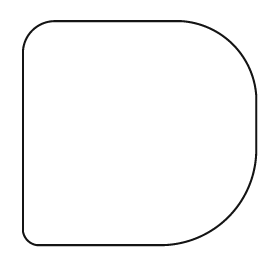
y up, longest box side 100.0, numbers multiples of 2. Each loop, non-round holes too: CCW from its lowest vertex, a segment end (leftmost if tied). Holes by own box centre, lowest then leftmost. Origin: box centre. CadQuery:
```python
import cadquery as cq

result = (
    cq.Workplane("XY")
    .moveTo(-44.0, -48.0)
    .lineTo(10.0, -48.0)
    .threePointArc((38.0, -36.0), (50.0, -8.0))
    .lineTo(50.0, 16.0)
    .threePointArc((40.0, 38.0), (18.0, 48.0))
    .lineTo(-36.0, 48.0)
    .threePointArc((-46.0, 44.0), (-50.0, 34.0))
    .lineTo(-50.0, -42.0)
    .threePointArc((-48.0, -46.0), (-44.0, -48.0))
    .close()
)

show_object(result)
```